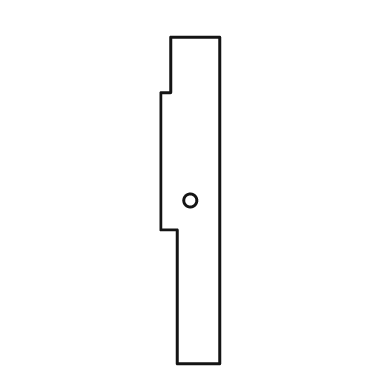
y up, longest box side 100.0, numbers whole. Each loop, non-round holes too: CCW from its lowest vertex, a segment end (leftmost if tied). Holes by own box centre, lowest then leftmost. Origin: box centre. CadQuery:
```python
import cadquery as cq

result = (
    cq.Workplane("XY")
    .moveTo(-4.0, -50.0)
    .lineTo(9.0, -50.0)
    .lineTo(9.0, 50.0)
    .lineTo(-6.0, 50.0)
    .lineTo(-6.0, 33.0)
    .lineTo(-9.0, 33.0)
    .lineTo(-9.0, -9.0)
    .lineTo(-4.0, -9.0)
    .close()
    .moveTo(0.0, 0.0)
    .circle(2.0)
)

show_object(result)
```